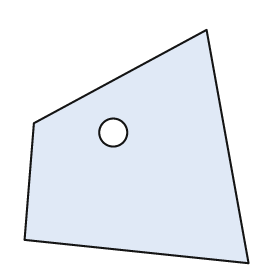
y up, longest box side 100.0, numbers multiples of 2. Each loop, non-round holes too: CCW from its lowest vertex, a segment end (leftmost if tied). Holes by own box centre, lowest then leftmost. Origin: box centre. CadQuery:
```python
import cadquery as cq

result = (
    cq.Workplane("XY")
    .moveTo(48.0, -50.0)
    .lineTo(30.0, 50.0)
    .lineTo(-44.0, 10.0)
    .lineTo(-48.0, -40.0)
    .close()
    .moveTo(-10.0, 6.0)
    .circle(6.0)
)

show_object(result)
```